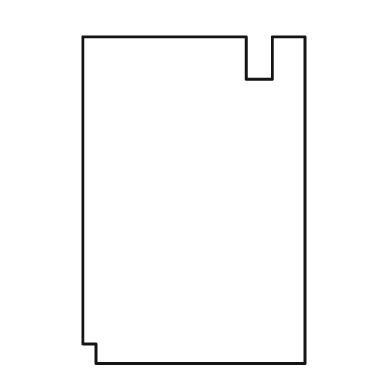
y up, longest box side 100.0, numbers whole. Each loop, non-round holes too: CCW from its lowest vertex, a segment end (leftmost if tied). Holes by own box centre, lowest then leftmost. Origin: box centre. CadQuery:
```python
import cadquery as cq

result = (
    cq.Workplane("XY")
    .moveTo(-30.0, -50.0)
    .lineTo(34.0, -50.0)
    .lineTo(34.0, 50.0)
    .lineTo(24.0, 50.0)
    .lineTo(24.0, 37.0)
    .lineTo(16.0, 37.0)
    .lineTo(16.0, 50.0)
    .lineTo(-34.0, 50.0)
    .lineTo(-34.0, -44.0)
    .lineTo(-30.0, -44.0)
    .close()
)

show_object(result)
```